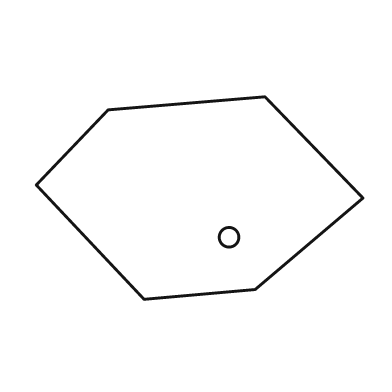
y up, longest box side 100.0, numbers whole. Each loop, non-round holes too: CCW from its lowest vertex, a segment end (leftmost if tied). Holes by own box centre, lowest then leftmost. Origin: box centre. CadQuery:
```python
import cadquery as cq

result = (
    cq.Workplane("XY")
    .moveTo(-17.0, -31.0)
    .lineTo(17.0, -28.0)
    .lineTo(50.0, 0.0)
    .lineTo(20.0, 31.0)
    .lineTo(-28.0, 27.0)
    .lineTo(-50.0, 4.0)
    .close()
    .moveTo(9.0, -12.0)
    .circle(3.0)
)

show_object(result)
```